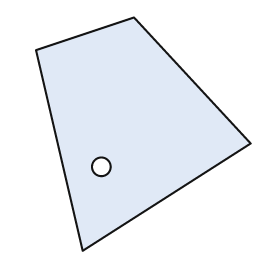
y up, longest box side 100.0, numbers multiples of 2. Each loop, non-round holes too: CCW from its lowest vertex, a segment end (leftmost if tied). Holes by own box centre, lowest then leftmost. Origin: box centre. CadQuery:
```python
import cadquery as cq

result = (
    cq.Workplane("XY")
    .moveTo(-26.0, -50.0)
    .lineTo(46.0, -4.0)
    .lineTo(-4.0, 50.0)
    .lineTo(-46.0, 36.0)
    .close()
    .moveTo(-18.0, -14.0)
    .circle(4.0)
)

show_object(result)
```